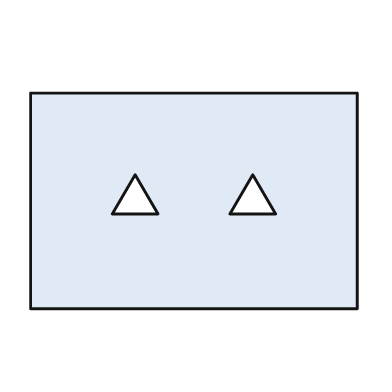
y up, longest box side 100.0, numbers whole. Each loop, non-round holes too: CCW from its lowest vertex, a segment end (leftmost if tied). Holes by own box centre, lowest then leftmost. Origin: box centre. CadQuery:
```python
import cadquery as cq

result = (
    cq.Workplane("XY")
    .moveTo(-50.0, -33.0)
    .lineTo(50.0, -33.0)
    .lineTo(50.0, 33.0)
    .lineTo(-50.0, 33.0)
    .close()
    .moveTo(-25.0, -4.0)
    .lineTo(-11.0, -4.0)
    .lineTo(-18.0, 8.0)
    .close()
    .moveTo(11.0, -4.0)
    .lineTo(25.0, -4.0)
    .lineTo(18.0, 8.0)
    .close()
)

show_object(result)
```